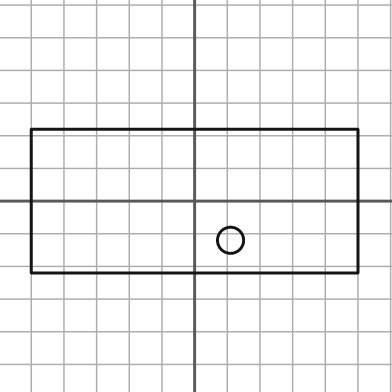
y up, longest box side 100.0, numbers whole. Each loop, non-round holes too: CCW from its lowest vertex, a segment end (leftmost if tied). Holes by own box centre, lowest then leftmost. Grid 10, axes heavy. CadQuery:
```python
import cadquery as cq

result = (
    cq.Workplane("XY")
    .moveTo(-50.0, -22.0)
    .lineTo(50.0, -22.0)
    .lineTo(50.0, 22.0)
    .lineTo(-50.0, 22.0)
    .close()
    .moveTo(11.0, -12.0)
    .circle(4.0)
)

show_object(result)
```